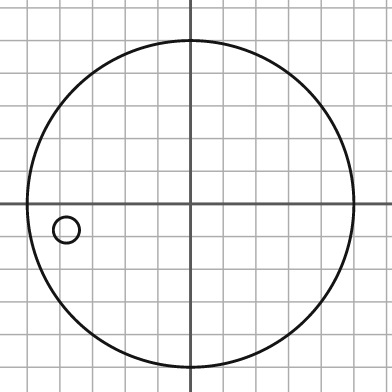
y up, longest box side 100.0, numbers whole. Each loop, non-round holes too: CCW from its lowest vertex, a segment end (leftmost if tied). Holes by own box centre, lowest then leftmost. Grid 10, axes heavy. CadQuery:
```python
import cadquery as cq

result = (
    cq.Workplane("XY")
    .moveTo(0.0, 0.0)
    .circle(50.0)
    .moveTo(-38.0, -8.0)
    .circle(4.0)
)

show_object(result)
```